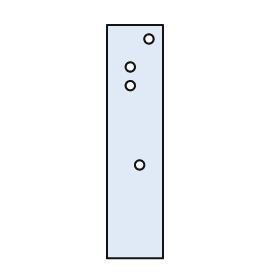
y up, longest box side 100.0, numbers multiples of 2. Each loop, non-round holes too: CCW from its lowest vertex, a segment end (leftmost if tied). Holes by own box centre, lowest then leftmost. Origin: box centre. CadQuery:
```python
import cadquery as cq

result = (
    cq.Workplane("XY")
    .moveTo(-12.0, -50.0)
    .lineTo(12.0, -50.0)
    .lineTo(12.0, 50.0)
    .lineTo(-12.0, 50.0)
    .close()
    .moveTo(2.0, -10.0)
    .circle(2.0)
    .moveTo(-2.0, 24.0)
    .circle(2.0)
    .moveTo(-2.0, 32.0)
    .circle(2.0)
    .moveTo(6.0, 44.0)
    .circle(2.0)
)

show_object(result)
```